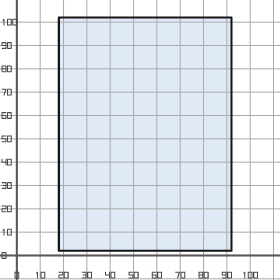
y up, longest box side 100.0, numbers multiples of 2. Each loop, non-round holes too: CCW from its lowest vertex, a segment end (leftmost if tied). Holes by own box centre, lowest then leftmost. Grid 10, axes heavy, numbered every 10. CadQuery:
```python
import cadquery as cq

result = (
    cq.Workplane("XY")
    .moveTo(18.0, 2.0)
    .lineTo(92.0, 2.0)
    .lineTo(92.0, 102.0)
    .lineTo(18.0, 102.0)
    .close()
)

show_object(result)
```